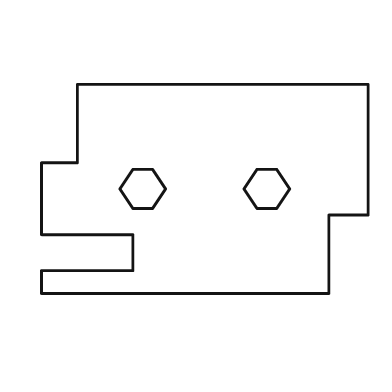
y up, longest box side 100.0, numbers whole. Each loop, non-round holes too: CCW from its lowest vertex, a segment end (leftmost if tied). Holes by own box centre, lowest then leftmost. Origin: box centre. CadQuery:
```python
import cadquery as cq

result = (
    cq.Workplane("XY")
    .moveTo(-50.0, -32.0)
    .lineTo(38.0, -32.0)
    .lineTo(38.0, -8.0)
    .lineTo(50.0, -8.0)
    .lineTo(50.0, 32.0)
    .lineTo(-39.0, 32.0)
    .lineTo(-39.0, 8.0)
    .lineTo(-50.0, 8.0)
    .lineTo(-50.0, -14.0)
    .lineTo(-22.0, -14.0)
    .lineTo(-22.0, -25.0)
    .lineTo(-50.0, -25.0)
    .close()
    .moveTo(-22.0, -6.0)
    .lineTo(-16.0, -6.0)
    .lineTo(-12.0, 0.0)
    .lineTo(-16.0, 6.0)
    .lineTo(-22.0, 6.0)
    .lineTo(-26.0, 0.0)
    .close()
    .moveTo(16.0, -6.0)
    .lineTo(22.0, -6.0)
    .lineTo(26.0, 0.0)
    .lineTo(22.0, 6.0)
    .lineTo(16.0, 6.0)
    .lineTo(12.0, 0.0)
    .close()
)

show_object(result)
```